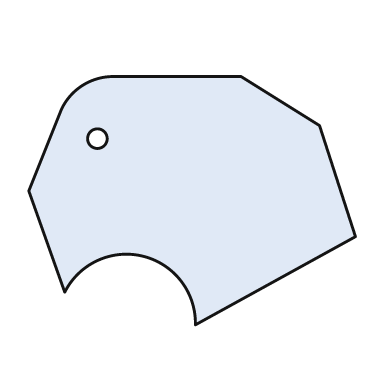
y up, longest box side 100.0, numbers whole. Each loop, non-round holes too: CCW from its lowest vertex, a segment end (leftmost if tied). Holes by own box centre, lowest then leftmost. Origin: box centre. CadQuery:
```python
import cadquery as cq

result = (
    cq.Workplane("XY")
    .moveTo(1.0, -38.0)
    .lineTo(50.0, -11.0)
    .lineTo(39.0, 23.0)
    .lineTo(15.0, 38.0)
    .lineTo(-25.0, 38.0)
    .threePointArc((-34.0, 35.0), (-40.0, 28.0))
    .lineTo(-50.0, 3.0)
    .lineTo(-39.0, -28.0)
    .threePointArc((-15.0, -17.0), (1.0, -38.0))
    .close()
    .moveTo(-29.0, 19.0)
    .circle(3.0)
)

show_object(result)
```